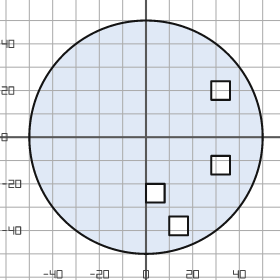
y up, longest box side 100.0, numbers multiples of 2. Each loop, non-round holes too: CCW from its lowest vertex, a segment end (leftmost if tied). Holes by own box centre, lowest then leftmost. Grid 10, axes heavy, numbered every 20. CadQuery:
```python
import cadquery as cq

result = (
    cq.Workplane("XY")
    .moveTo(0.0, 0.0)
    .circle(50.0)
    .moveTo(10.0, -42.0)
    .lineTo(18.0, -42.0)
    .lineTo(18.0, -34.0)
    .lineTo(10.0, -34.0)
    .close()
    .moveTo(0.0, -28.0)
    .lineTo(8.0, -28.0)
    .lineTo(8.0, -20.0)
    .lineTo(0.0, -20.0)
    .close()
    .moveTo(28.0, -16.0)
    .lineTo(36.0, -16.0)
    .lineTo(36.0, -8.0)
    .lineTo(28.0, -8.0)
    .close()
    .moveTo(28.0, 16.0)
    .lineTo(36.0, 16.0)
    .lineTo(36.0, 24.0)
    .lineTo(28.0, 24.0)
    .close()
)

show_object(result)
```